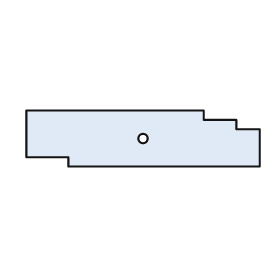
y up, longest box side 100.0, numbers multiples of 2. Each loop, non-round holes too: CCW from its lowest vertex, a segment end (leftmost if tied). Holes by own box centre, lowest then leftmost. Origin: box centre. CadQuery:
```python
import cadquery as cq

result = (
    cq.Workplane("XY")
    .moveTo(-32.0, -12.0)
    .lineTo(50.0, -12.0)
    .lineTo(50.0, 4.0)
    .lineTo(40.0, 4.0)
    .lineTo(40.0, 8.0)
    .lineTo(26.0, 8.0)
    .lineTo(26.0, 12.0)
    .lineTo(-50.0, 12.0)
    .lineTo(-50.0, -8.0)
    .lineTo(-32.0, -8.0)
    .close()
    .moveTo(0.0, 0.0)
    .circle(2.0)
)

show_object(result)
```